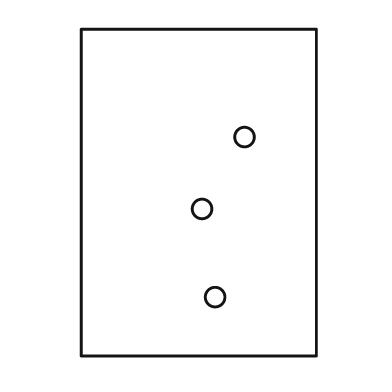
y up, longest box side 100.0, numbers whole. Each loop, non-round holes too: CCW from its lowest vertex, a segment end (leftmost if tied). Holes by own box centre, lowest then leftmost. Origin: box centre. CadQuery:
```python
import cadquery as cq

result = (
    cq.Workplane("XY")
    .moveTo(-36.0, -50.0)
    .lineTo(36.0, -50.0)
    .lineTo(36.0, 50.0)
    .lineTo(-36.0, 50.0)
    .close()
    .moveTo(5.0, -32.0)
    .circle(3.0)
    .moveTo(1.0, -5.0)
    .circle(3.0)
    .moveTo(14.0, 17.0)
    .circle(3.0)
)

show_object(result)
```